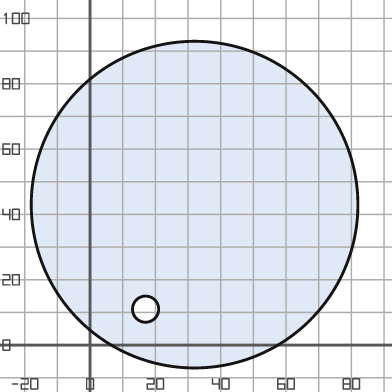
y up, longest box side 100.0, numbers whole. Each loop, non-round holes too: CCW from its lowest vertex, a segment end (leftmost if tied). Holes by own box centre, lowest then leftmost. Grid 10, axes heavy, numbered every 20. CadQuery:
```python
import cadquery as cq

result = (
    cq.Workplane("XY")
    .moveTo(32.0, 43.0)
    .circle(50.0)
    .moveTo(17.0, 11.0)
    .circle(4.0)
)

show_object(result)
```